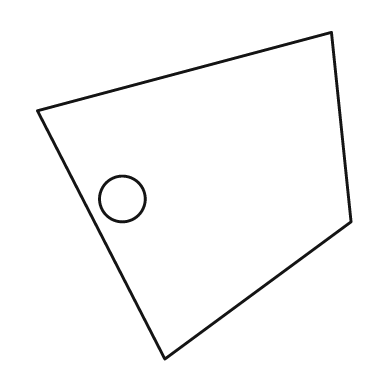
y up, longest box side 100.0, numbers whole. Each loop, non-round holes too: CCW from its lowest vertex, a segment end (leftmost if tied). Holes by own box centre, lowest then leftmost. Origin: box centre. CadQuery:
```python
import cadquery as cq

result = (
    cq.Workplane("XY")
    .moveTo(-9.0, -50.0)
    .lineTo(48.0, -8.0)
    .lineTo(42.0, 50.0)
    .lineTo(-48.0, 26.0)
    .close()
    .moveTo(-22.0, -1.0)
    .circle(7.0)
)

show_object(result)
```